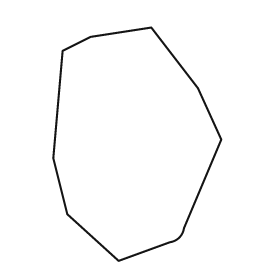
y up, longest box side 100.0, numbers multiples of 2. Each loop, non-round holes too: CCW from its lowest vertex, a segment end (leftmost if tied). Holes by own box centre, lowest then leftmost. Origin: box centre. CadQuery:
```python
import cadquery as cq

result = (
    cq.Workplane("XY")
    .moveTo(-8.0, -50.0)
    .lineTo(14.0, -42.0)
    .threePointArc((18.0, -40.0), (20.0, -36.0))
    .lineTo(36.0, 2.0)
    .lineTo(26.0, 24.0)
    .lineTo(6.0, 50.0)
    .lineTo(-20.0, 46.0)
    .lineTo(-32.0, 40.0)
    .lineTo(-36.0, -6.0)
    .lineTo(-30.0, -30.0)
    .close()
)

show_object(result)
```